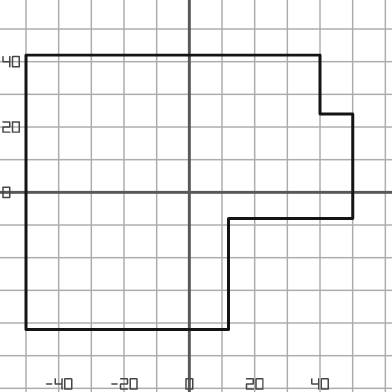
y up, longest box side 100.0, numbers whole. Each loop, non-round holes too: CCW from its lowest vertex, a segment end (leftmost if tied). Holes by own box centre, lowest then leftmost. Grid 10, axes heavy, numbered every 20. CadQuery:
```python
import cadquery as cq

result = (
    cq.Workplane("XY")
    .moveTo(-50.0, -42.0)
    .lineTo(12.0, -42.0)
    .lineTo(12.0, -8.0)
    .lineTo(50.0, -8.0)
    .lineTo(50.0, 24.0)
    .lineTo(40.0, 24.0)
    .lineTo(40.0, 42.0)
    .lineTo(-50.0, 42.0)
    .close()
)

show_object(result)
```